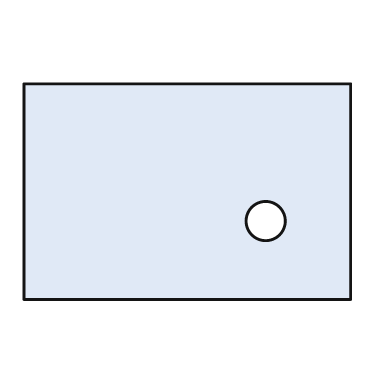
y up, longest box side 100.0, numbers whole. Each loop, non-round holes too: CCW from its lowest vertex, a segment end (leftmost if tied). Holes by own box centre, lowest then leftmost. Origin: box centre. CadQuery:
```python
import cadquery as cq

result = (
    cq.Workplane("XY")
    .moveTo(-50.0, -33.0)
    .lineTo(50.0, -33.0)
    .lineTo(50.0, 33.0)
    .lineTo(-50.0, 33.0)
    .close()
    .moveTo(24.0, -9.0)
    .circle(6.0)
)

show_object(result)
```